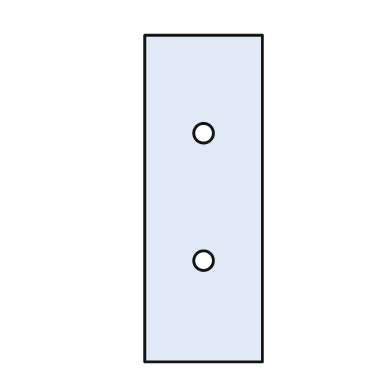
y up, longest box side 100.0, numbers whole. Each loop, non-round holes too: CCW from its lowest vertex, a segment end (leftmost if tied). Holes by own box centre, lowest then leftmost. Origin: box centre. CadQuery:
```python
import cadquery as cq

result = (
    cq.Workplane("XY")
    .moveTo(-18.0, -50.0)
    .lineTo(18.0, -50.0)
    .lineTo(18.0, 50.0)
    .lineTo(-18.0, 50.0)
    .close()
    .moveTo(0.0, -19.0)
    .circle(3.0)
    .moveTo(0.0, 20.0)
    .circle(3.0)
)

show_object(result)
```